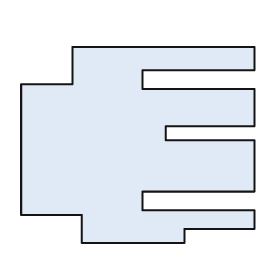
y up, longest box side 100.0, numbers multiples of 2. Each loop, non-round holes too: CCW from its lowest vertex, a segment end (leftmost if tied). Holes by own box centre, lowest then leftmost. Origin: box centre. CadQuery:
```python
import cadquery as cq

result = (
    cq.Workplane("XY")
    .moveTo(-24.0, -42.0)
    .lineTo(20.0, -42.0)
    .lineTo(20.0, -36.0)
    .lineTo(50.0, -36.0)
    .lineTo(50.0, -28.0)
    .lineTo(2.0, -28.0)
    .lineTo(2.0, -20.0)
    .lineTo(50.0, -20.0)
    .lineTo(50.0, 2.0)
    .lineTo(12.0, 2.0)
    .lineTo(12.0, 8.0)
    .lineTo(50.0, 8.0)
    .lineTo(50.0, 24.0)
    .lineTo(2.0, 24.0)
    .lineTo(2.0, 32.0)
    .lineTo(50.0, 32.0)
    .lineTo(50.0, 42.0)
    .lineTo(-28.0, 42.0)
    .lineTo(-28.0, 26.0)
    .lineTo(-50.0, 26.0)
    .lineTo(-50.0, -30.0)
    .lineTo(-24.0, -30.0)
    .close()
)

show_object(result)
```